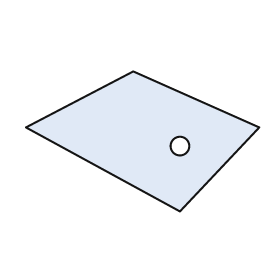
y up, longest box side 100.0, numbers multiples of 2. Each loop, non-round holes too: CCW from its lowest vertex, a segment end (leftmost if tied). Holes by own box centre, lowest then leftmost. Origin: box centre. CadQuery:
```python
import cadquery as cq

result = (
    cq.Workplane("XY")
    .moveTo(16.0, -30.0)
    .lineTo(50.0, 6.0)
    .lineTo(-4.0, 30.0)
    .lineTo(-50.0, 6.0)
    .close()
    .moveTo(16.0, -2.0)
    .circle(4.0)
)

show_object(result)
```